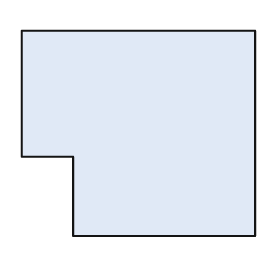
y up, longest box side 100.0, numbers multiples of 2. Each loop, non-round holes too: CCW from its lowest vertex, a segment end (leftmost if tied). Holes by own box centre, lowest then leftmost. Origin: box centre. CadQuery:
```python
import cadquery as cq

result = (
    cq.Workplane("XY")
    .moveTo(-28.0, -44.0)
    .lineTo(50.0, -44.0)
    .lineTo(50.0, 44.0)
    .lineTo(-50.0, 44.0)
    .lineTo(-50.0, -10.0)
    .lineTo(-28.0, -10.0)
    .close()
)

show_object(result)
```